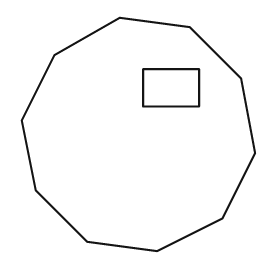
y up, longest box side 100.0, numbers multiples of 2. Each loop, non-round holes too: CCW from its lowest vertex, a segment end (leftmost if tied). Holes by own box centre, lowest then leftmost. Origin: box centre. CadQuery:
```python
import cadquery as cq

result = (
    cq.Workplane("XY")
    .moveTo(8.0, -50.0)
    .lineTo(36.0, -36.0)
    .lineTo(50.0, -8.0)
    .lineTo(44.0, 24.0)
    .lineTo(22.0, 46.0)
    .lineTo(-8.0, 50.0)
    .lineTo(-36.0, 34.0)
    .lineTo(-50.0, 6.0)
    .lineTo(-44.0, -24.0)
    .lineTo(-22.0, -46.0)
    .close()
    .moveTo(2.0, 12.0)
    .lineTo(26.0, 12.0)
    .lineTo(26.0, 28.0)
    .lineTo(2.0, 28.0)
    .close()
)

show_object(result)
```